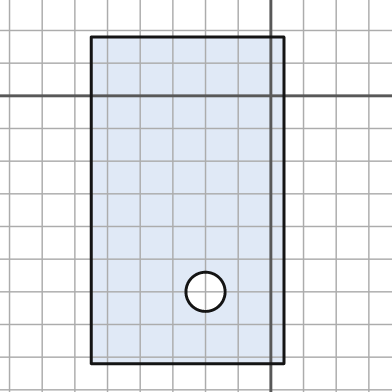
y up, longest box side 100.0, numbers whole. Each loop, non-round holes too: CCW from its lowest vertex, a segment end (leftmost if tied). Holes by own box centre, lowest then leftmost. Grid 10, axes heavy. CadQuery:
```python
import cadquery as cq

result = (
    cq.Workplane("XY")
    .moveTo(-55.0, -82.0)
    .lineTo(4.0, -82.0)
    .lineTo(4.0, 18.0)
    .lineTo(-55.0, 18.0)
    .close()
    .moveTo(-20.0, -60.0)
    .circle(6.0)
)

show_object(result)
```